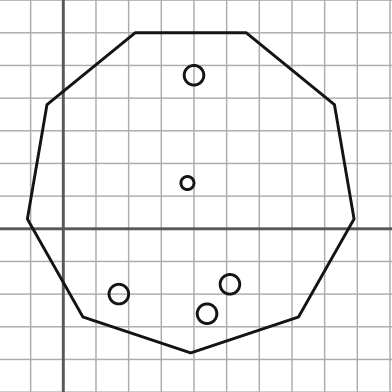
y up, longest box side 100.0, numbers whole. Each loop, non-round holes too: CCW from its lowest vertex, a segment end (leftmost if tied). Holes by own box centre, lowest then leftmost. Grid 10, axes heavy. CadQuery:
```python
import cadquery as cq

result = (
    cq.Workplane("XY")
    .moveTo(39.0, -38.0)
    .lineTo(72.0, -27.0)
    .lineTo(89.0, 3.0)
    .lineTo(83.0, 38.0)
    .lineTo(56.0, 60.0)
    .lineTo(22.0, 60.0)
    .lineTo(-5.0, 38.0)
    .lineTo(-11.0, 3.0)
    .lineTo(6.0, -27.0)
    .close()
    .moveTo(44.0, -26.0)
    .circle(3.0)
    .moveTo(17.0, -20.0)
    .circle(3.0)
    .moveTo(51.0, -17.0)
    .circle(3.0)
    .moveTo(38.0, 14.0)
    .circle(2.0)
    .moveTo(40.0, 47.0)
    .circle(3.0)
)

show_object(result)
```